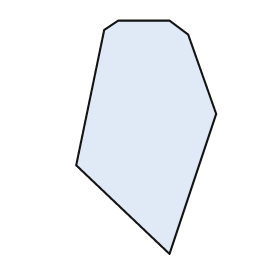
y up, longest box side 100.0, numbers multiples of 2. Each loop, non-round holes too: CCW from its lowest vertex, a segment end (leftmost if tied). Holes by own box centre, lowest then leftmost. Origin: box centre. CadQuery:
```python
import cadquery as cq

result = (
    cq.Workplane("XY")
    .moveTo(10.0, -50.0)
    .lineTo(30.0, 10.0)
    .lineTo(18.0, 44.0)
    .lineTo(10.0, 50.0)
    .lineTo(-12.0, 50.0)
    .lineTo(-18.0, 46.0)
    .lineTo(-30.0, -12.0)
    .close()
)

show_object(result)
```